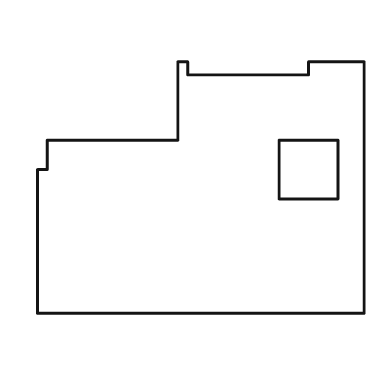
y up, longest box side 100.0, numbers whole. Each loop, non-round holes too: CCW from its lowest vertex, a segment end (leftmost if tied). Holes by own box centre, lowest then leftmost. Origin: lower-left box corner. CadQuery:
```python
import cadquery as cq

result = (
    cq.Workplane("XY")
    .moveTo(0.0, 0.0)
    .lineTo(100.0, 0.0)
    .lineTo(100.0, 77.0)
    .lineTo(83.0, 77.0)
    .lineTo(83.0, 73.0)
    .lineTo(46.0, 73.0)
    .lineTo(46.0, 77.0)
    .lineTo(43.0, 77.0)
    .lineTo(43.0, 53.0)
    .lineTo(3.0, 53.0)
    .lineTo(3.0, 44.0)
    .lineTo(0.0, 44.0)
    .close()
    .moveTo(74.0, 35.0)
    .lineTo(92.0, 35.0)
    .lineTo(92.0, 53.0)
    .lineTo(74.0, 53.0)
    .close()
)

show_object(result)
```